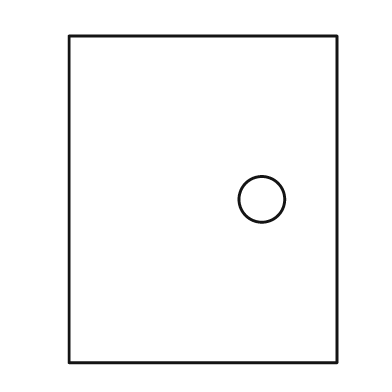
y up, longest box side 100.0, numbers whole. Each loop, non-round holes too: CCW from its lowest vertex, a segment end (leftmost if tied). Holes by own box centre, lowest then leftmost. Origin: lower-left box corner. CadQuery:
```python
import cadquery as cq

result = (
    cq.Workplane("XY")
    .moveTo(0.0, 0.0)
    .lineTo(82.0, 0.0)
    .lineTo(82.0, 100.0)
    .lineTo(0.0, 100.0)
    .close()
    .moveTo(59.0, 50.0)
    .circle(7.0)
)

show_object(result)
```